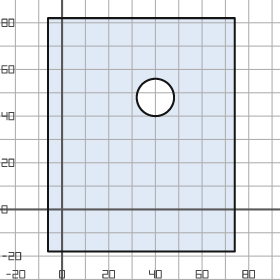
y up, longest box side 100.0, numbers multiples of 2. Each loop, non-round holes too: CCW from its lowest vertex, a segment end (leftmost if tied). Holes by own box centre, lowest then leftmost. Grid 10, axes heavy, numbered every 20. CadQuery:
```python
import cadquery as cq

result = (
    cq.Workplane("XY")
    .moveTo(-6.0, -18.0)
    .lineTo(74.0, -18.0)
    .lineTo(74.0, 82.0)
    .lineTo(-6.0, 82.0)
    .close()
    .moveTo(40.0, 48.0)
    .circle(8.0)
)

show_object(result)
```